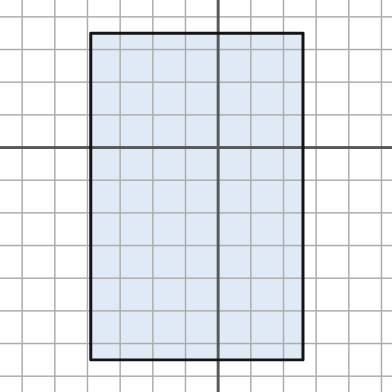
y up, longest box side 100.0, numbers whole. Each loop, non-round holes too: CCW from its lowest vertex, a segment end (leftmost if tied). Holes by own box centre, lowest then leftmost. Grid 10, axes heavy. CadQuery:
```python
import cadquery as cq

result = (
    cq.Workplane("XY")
    .moveTo(-39.0, -65.0)
    .lineTo(26.0, -65.0)
    .lineTo(26.0, 35.0)
    .lineTo(-39.0, 35.0)
    .close()
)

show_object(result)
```